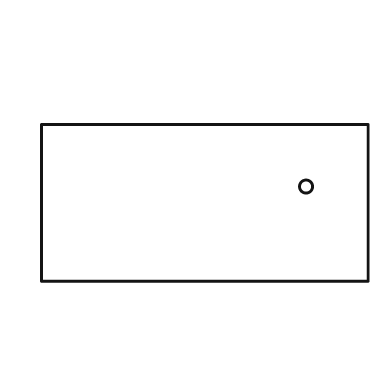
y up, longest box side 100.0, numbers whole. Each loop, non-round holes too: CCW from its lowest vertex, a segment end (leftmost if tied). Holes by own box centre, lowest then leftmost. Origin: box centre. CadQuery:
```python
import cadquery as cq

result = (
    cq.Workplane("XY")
    .moveTo(-50.0, -24.0)
    .lineTo(50.0, -24.0)
    .lineTo(50.0, 24.0)
    .lineTo(-50.0, 24.0)
    .close()
    .moveTo(31.0, 5.0)
    .circle(2.0)
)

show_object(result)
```